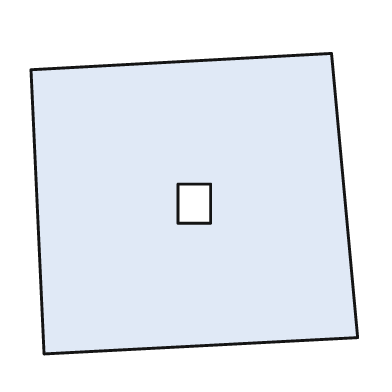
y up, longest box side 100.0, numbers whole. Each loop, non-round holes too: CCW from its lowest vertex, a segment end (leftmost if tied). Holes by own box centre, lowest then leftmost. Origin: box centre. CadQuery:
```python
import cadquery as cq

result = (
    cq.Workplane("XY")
    .moveTo(-46.0, -46.0)
    .lineTo(50.0, -41.0)
    .lineTo(42.0, 46.0)
    .lineTo(-50.0, 41.0)
    .close()
    .moveTo(-5.0, -6.0)
    .lineTo(5.0, -6.0)
    .lineTo(5.0, 6.0)
    .lineTo(-5.0, 6.0)
    .close()
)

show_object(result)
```